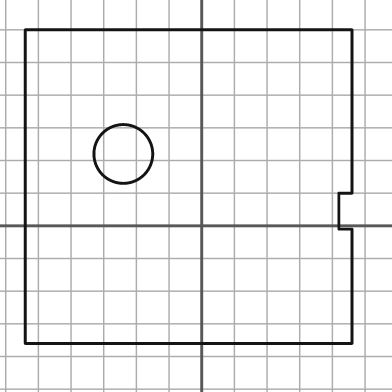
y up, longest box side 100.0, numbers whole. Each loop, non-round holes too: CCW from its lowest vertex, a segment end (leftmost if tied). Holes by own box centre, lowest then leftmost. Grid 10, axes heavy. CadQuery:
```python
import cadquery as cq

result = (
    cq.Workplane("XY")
    .moveTo(-54.0, -36.0)
    .lineTo(46.0, -36.0)
    .lineTo(46.0, -1.0)
    .lineTo(42.0, -1.0)
    .lineTo(42.0, 10.0)
    .lineTo(46.0, 10.0)
    .lineTo(46.0, 60.0)
    .lineTo(-54.0, 60.0)
    .close()
    .moveTo(-24.0, 22.0)
    .circle(9.0)
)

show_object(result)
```